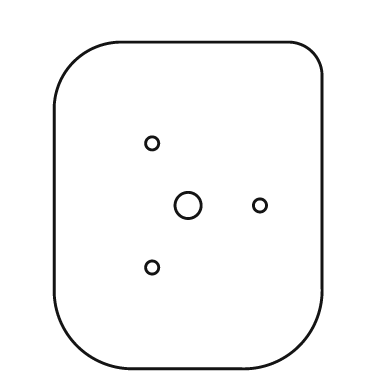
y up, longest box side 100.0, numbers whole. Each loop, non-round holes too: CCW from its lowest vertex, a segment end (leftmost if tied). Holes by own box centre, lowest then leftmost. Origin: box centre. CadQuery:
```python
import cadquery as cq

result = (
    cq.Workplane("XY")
    .moveTo(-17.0, -50.0)
    .lineTo(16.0, -50.0)
    .threePointArc((34.0, -43.0), (41.0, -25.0))
    .lineTo(41.0, 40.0)
    .threePointArc((38.0, 47.0), (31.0, 50.0))
    .lineTo(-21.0, 50.0)
    .threePointArc((-35.0, 44.0), (-41.0, 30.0))
    .lineTo(-41.0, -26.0)
    .threePointArc((-34.0, -43.0), (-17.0, -50.0))
    .close()
    .moveTo(-11.0, -19.0)
    .circle(2.0)
    .moveTo(0.0, 0.0)
    .circle(4.0)
    .moveTo(22.0, 0.0)
    .circle(2.0)
    .moveTo(-11.0, 19.0)
    .circle(2.0)
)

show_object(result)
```